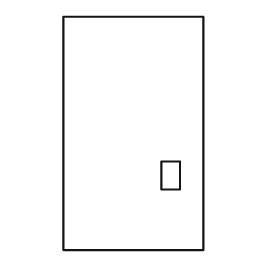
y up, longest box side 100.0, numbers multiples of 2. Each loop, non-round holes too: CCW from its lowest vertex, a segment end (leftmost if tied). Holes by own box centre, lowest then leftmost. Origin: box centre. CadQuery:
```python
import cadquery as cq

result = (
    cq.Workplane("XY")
    .moveTo(-30.0, -50.0)
    .lineTo(30.0, -50.0)
    .lineTo(30.0, 50.0)
    .lineTo(-30.0, 50.0)
    .close()
    .moveTo(12.0, -24.0)
    .lineTo(20.0, -24.0)
    .lineTo(20.0, -12.0)
    .lineTo(12.0, -12.0)
    .close()
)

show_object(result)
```